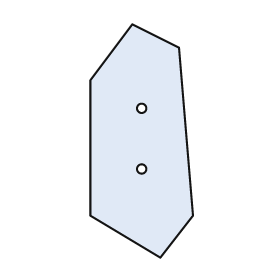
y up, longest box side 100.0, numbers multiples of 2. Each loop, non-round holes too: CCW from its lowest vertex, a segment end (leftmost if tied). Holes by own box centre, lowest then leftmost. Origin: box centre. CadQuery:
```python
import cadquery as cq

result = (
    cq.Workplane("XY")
    .moveTo(8.0, -50.0)
    .lineTo(22.0, -32.0)
    .lineTo(16.0, 40.0)
    .lineTo(-4.0, 50.0)
    .lineTo(-22.0, 26.0)
    .lineTo(-22.0, -32.0)
    .close()
    .moveTo(0.0, -12.0)
    .circle(2.0)
    .moveTo(0.0, 14.0)
    .circle(2.0)
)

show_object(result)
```